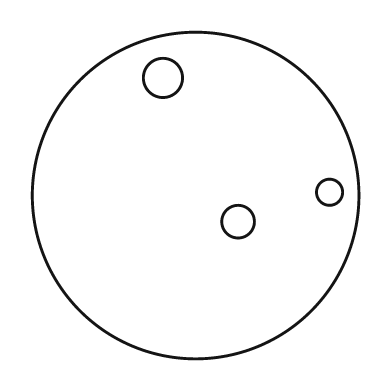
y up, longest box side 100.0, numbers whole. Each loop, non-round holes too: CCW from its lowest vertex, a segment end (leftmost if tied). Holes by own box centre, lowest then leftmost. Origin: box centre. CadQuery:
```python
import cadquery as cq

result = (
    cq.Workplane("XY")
    .moveTo(0.0, 0.0)
    .circle(50.0)
    .moveTo(13.0, -8.0)
    .circle(5.0)
    .moveTo(41.0, 1.0)
    .circle(4.0)
    .moveTo(-10.0, 36.0)
    .circle(6.0)
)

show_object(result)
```